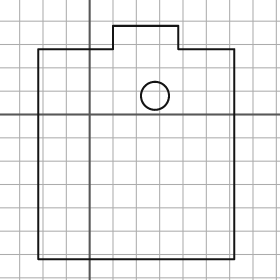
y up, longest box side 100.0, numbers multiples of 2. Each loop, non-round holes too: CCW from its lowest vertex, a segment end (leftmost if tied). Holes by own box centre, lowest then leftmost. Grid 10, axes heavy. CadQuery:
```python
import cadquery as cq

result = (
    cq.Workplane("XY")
    .moveTo(-22.0, -62.0)
    .lineTo(62.0, -62.0)
    .lineTo(62.0, 28.0)
    .lineTo(38.0, 28.0)
    .lineTo(38.0, 38.0)
    .lineTo(10.0, 38.0)
    .lineTo(10.0, 28.0)
    .lineTo(-22.0, 28.0)
    .close()
    .moveTo(28.0, 8.0)
    .circle(6.0)
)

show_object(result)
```